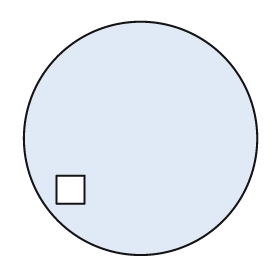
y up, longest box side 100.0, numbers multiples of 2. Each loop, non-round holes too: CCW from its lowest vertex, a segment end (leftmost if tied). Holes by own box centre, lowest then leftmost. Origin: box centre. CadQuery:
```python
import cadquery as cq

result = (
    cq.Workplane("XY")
    .moveTo(0.0, 0.0)
    .circle(50.0)
    .moveTo(-36.0, -28.0)
    .lineTo(-24.0, -28.0)
    .lineTo(-24.0, -16.0)
    .lineTo(-36.0, -16.0)
    .close()
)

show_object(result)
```